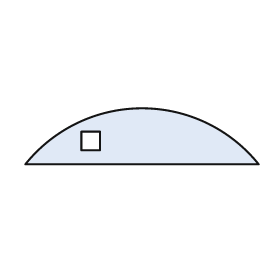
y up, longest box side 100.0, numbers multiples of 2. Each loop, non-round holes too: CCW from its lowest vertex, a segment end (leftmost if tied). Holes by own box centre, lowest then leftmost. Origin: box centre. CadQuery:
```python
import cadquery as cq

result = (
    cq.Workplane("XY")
    .moveTo(-50.0, -12.0)
    .lineTo(50.0, -12.0)
    .threePointArc((0.0, 12.0), (-50.0, -12.0))
    .close()
    .moveTo(-26.0, -6.0)
    .lineTo(-18.0, -6.0)
    .lineTo(-18.0, 2.0)
    .lineTo(-26.0, 2.0)
    .close()
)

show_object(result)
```